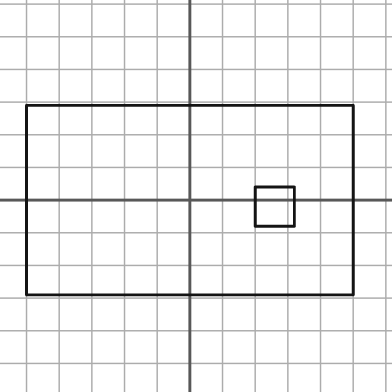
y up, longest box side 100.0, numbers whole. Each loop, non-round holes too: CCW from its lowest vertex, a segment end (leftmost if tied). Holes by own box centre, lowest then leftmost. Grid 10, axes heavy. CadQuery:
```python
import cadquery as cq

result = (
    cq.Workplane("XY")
    .moveTo(-50.0, -29.0)
    .lineTo(50.0, -29.0)
    .lineTo(50.0, 29.0)
    .lineTo(-50.0, 29.0)
    .close()
    .moveTo(20.0, -8.0)
    .lineTo(32.0, -8.0)
    .lineTo(32.0, 4.0)
    .lineTo(20.0, 4.0)
    .close()
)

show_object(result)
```